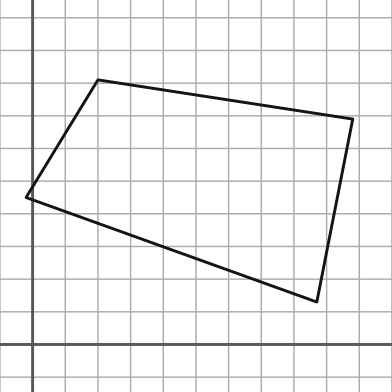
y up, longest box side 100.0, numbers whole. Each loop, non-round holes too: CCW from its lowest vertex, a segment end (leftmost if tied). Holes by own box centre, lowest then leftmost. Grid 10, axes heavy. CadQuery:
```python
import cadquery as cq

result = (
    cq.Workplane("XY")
    .moveTo(87.0, 13.0)
    .lineTo(98.0, 69.0)
    .lineTo(20.0, 81.0)
    .lineTo(-2.0, 45.0)
    .close()
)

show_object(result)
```